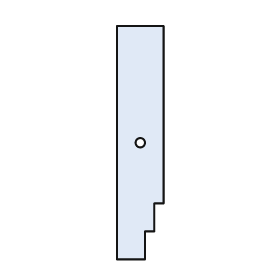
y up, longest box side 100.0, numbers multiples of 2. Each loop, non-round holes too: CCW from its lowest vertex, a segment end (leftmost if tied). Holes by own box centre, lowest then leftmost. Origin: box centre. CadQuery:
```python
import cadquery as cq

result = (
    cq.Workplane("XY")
    .moveTo(-10.0, -50.0)
    .lineTo(2.0, -50.0)
    .lineTo(2.0, -38.0)
    .lineTo(6.0, -38.0)
    .lineTo(6.0, -26.0)
    .lineTo(10.0, -26.0)
    .lineTo(10.0, 50.0)
    .lineTo(-10.0, 50.0)
    .close()
    .moveTo(0.0, 0.0)
    .circle(2.0)
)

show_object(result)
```